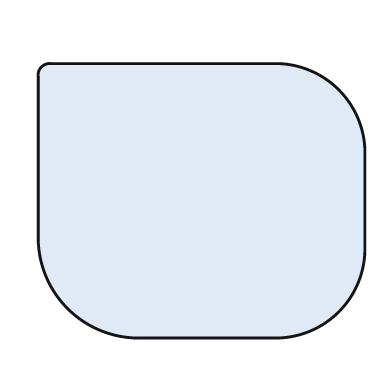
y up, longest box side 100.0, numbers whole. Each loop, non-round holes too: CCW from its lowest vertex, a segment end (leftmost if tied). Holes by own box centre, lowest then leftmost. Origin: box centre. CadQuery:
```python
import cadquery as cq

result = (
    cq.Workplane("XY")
    .moveTo(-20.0, -42.0)
    .lineTo(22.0, -42.0)
    .threePointArc((42.0, -34.0), (50.0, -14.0))
    .lineTo(50.0, 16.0)
    .threePointArc((42.0, 34.0), (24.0, 42.0))
    .lineTo(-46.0, 42.0)
    .threePointArc((-49.0, 41.0), (-50.0, 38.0))
    .lineTo(-50.0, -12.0)
    .threePointArc((-41.0, -33.0), (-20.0, -42.0))
    .close()
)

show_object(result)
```